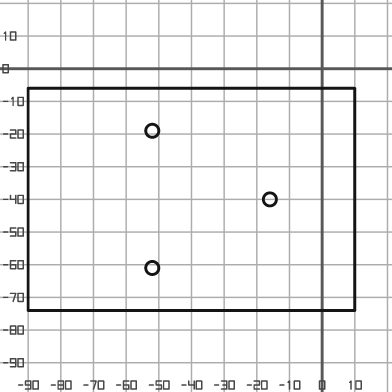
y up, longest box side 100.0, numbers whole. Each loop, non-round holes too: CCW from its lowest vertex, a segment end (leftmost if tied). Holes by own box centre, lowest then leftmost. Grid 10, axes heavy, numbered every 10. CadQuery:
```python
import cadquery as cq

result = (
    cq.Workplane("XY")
    .moveTo(-90.0, -74.0)
    .lineTo(10.0, -74.0)
    .lineTo(10.0, -6.0)
    .lineTo(-90.0, -6.0)
    .close()
    .moveTo(-52.0, -61.0)
    .circle(2.0)
    .moveTo(-16.0, -40.0)
    .circle(2.0)
    .moveTo(-52.0, -19.0)
    .circle(2.0)
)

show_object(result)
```